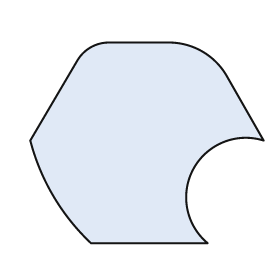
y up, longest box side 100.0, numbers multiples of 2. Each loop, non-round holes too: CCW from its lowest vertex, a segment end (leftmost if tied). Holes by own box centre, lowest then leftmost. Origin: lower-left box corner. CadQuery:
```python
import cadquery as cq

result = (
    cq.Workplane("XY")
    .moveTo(26.0, 0.0)
    .lineTo(76.0, 0.0)
    .threePointArc((70.0, 32.0), (100.0, 44.0))
    .lineTo(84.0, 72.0)
    .threePointArc((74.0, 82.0), (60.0, 86.0))
    .lineTo(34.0, 86.0)
    .threePointArc((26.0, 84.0), (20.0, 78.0))
    .lineTo(0.0, 44.0)
    .threePointArc((10.0, 20.0), (26.0, 0.0))
    .close()
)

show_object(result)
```